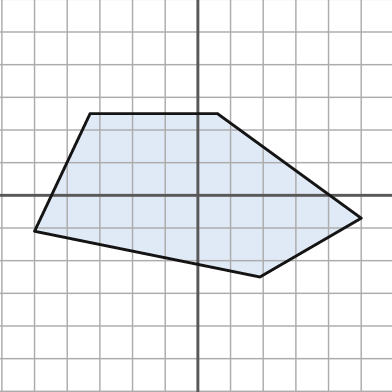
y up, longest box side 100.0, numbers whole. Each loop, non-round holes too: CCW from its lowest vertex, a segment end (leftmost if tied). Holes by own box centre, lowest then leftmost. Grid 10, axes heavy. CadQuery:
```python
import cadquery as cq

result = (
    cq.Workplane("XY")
    .moveTo(19.0, -25.0)
    .lineTo(50.0, -7.0)
    .lineTo(6.0, 25.0)
    .lineTo(-33.0, 25.0)
    .lineTo(-50.0, -11.0)
    .close()
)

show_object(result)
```